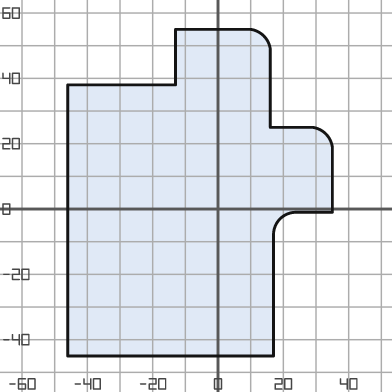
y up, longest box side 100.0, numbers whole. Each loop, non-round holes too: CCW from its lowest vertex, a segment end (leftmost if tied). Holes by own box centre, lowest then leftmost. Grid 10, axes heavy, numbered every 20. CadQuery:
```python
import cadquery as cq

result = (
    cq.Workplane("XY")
    .moveTo(-46.0, -45.0)
    .lineTo(17.0, -45.0)
    .lineTo(17.0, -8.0)
    .threePointArc((19.0, -3.0), (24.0, -1.0))
    .lineTo(35.0, -1.0)
    .lineTo(35.0, 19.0)
    .threePointArc((33.0, 23.0), (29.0, 25.0))
    .lineTo(16.0, 25.0)
    .lineTo(16.0, 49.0)
    .threePointArc((14.0, 53.0), (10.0, 55.0))
    .lineTo(-13.0, 55.0)
    .lineTo(-13.0, 38.0)
    .lineTo(-46.0, 38.0)
    .close()
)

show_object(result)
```